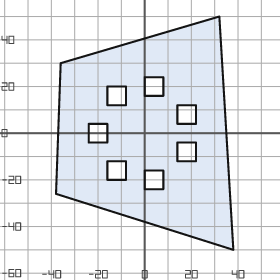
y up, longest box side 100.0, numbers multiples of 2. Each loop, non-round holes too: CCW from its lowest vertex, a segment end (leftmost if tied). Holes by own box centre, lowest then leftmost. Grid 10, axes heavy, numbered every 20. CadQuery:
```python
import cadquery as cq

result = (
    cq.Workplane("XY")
    .moveTo(38.0, -50.0)
    .lineTo(32.0, 50.0)
    .lineTo(-36.0, 30.0)
    .lineTo(-38.0, -26.0)
    .close()
    .moveTo(0.0, -24.0)
    .lineTo(8.0, -24.0)
    .lineTo(8.0, -16.0)
    .lineTo(0.0, -16.0)
    .close()
    .moveTo(-16.0, -20.0)
    .lineTo(-8.0, -20.0)
    .lineTo(-8.0, -12.0)
    .lineTo(-16.0, -12.0)
    .close()
    .moveTo(14.0, -12.0)
    .lineTo(22.0, -12.0)
    .lineTo(22.0, -4.0)
    .lineTo(14.0, -4.0)
    .close()
    .moveTo(-24.0, -4.0)
    .lineTo(-16.0, -4.0)
    .lineTo(-16.0, 4.0)
    .lineTo(-24.0, 4.0)
    .close()
    .moveTo(14.0, 4.0)
    .lineTo(22.0, 4.0)
    .lineTo(22.0, 12.0)
    .lineTo(14.0, 12.0)
    .close()
    .moveTo(-16.0, 12.0)
    .lineTo(-8.0, 12.0)
    .lineTo(-8.0, 20.0)
    .lineTo(-16.0, 20.0)
    .close()
    .moveTo(0.0, 16.0)
    .lineTo(8.0, 16.0)
    .lineTo(8.0, 24.0)
    .lineTo(0.0, 24.0)
    .close()
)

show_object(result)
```